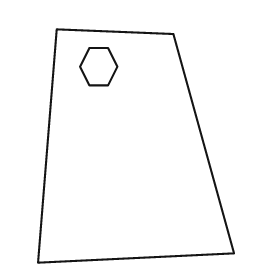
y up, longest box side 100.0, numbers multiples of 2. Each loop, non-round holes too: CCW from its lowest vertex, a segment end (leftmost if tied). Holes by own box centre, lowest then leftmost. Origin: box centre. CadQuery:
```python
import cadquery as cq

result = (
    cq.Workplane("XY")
    .moveTo(-42.0, -50.0)
    .lineTo(42.0, -46.0)
    .lineTo(16.0, 48.0)
    .lineTo(-34.0, 50.0)
    .close()
    .moveTo(-20.0, 26.0)
    .lineTo(-12.0, 26.0)
    .lineTo(-8.0, 34.0)
    .lineTo(-12.0, 42.0)
    .lineTo(-20.0, 42.0)
    .lineTo(-24.0, 34.0)
    .close()
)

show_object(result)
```